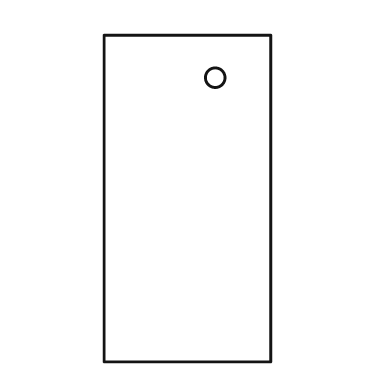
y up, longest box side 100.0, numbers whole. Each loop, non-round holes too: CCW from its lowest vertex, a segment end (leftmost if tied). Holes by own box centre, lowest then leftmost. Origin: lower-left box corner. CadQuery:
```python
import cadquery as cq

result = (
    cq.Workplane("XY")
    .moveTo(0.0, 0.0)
    .lineTo(51.0, 0.0)
    .lineTo(51.0, 100.0)
    .lineTo(0.0, 100.0)
    .close()
    .moveTo(34.0, 87.0)
    .circle(3.0)
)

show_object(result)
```